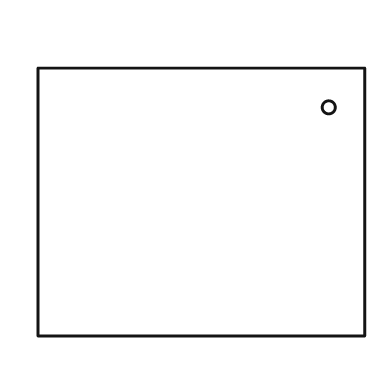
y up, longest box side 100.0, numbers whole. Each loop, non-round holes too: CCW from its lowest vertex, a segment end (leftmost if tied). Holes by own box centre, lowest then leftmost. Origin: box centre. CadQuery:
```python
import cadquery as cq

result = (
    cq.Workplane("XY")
    .moveTo(-50.0, -41.0)
    .lineTo(50.0, -41.0)
    .lineTo(50.0, 41.0)
    .lineTo(-50.0, 41.0)
    .close()
    .moveTo(39.0, 29.0)
    .circle(2.0)
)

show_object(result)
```